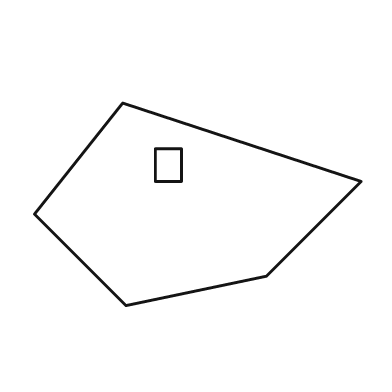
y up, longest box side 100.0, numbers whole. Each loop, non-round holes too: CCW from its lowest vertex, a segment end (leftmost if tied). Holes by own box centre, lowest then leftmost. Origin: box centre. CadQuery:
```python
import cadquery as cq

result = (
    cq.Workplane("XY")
    .moveTo(-22.0, -31.0)
    .lineTo(21.0, -22.0)
    .lineTo(50.0, 7.0)
    .lineTo(-23.0, 31.0)
    .lineTo(-50.0, -3.0)
    .close()
    .moveTo(-13.0, 7.0)
    .lineTo(-5.0, 7.0)
    .lineTo(-5.0, 17.0)
    .lineTo(-13.0, 17.0)
    .close()
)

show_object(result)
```